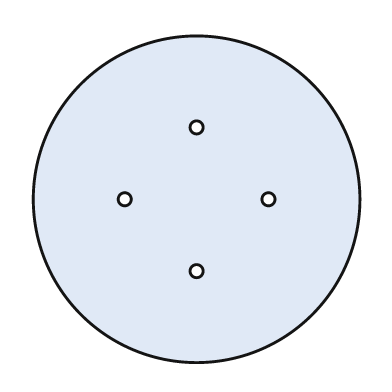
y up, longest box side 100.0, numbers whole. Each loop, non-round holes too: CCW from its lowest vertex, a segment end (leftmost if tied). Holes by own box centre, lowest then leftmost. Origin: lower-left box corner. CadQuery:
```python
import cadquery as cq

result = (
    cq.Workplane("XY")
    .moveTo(50.0, 50.0)
    .circle(50.0)
    .moveTo(50.0, 28.0)
    .circle(2.0)
    .moveTo(28.0, 50.0)
    .circle(2.0)
    .moveTo(72.0, 50.0)
    .circle(2.0)
    .moveTo(50.0, 72.0)
    .circle(2.0)
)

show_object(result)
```